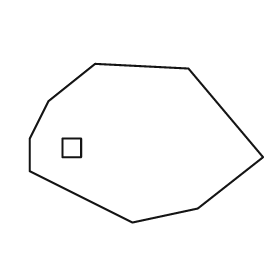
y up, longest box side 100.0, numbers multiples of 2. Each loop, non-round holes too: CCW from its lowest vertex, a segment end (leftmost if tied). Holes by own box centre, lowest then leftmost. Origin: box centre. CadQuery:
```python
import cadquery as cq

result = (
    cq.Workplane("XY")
    .moveTo(-6.0, -34.0)
    .lineTo(22.0, -28.0)
    .lineTo(50.0, -6.0)
    .lineTo(18.0, 32.0)
    .lineTo(-22.0, 34.0)
    .lineTo(-42.0, 18.0)
    .lineTo(-50.0, 2.0)
    .lineTo(-50.0, -12.0)
    .close()
    .moveTo(-36.0, -6.0)
    .lineTo(-28.0, -6.0)
    .lineTo(-28.0, 2.0)
    .lineTo(-36.0, 2.0)
    .close()
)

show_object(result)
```